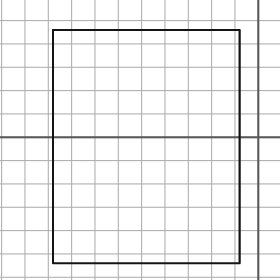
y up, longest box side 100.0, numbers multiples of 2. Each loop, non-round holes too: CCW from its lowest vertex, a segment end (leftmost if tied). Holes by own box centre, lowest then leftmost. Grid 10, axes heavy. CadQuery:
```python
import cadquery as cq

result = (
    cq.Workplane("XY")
    .moveTo(-88.0, -54.0)
    .lineTo(-8.0, -54.0)
    .lineTo(-8.0, 46.0)
    .lineTo(-88.0, 46.0)
    .close()
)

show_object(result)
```